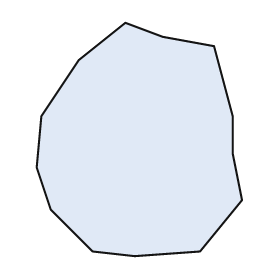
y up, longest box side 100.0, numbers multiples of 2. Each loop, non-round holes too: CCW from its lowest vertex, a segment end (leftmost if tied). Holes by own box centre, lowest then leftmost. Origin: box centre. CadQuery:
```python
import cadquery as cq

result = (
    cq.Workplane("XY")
    .moveTo(-2.0, -50.0)
    .lineTo(26.0, -48.0)
    .lineTo(44.0, -26.0)
    .lineTo(40.0, -6.0)
    .lineTo(40.0, 10.0)
    .lineTo(32.0, 40.0)
    .lineTo(10.0, 44.0)
    .lineTo(-6.0, 50.0)
    .lineTo(-26.0, 34.0)
    .lineTo(-42.0, 10.0)
    .lineTo(-44.0, -12.0)
    .lineTo(-38.0, -30.0)
    .lineTo(-20.0, -48.0)
    .close()
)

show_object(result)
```